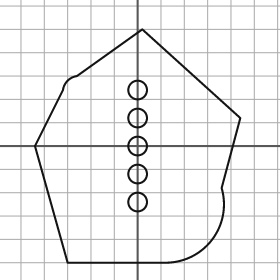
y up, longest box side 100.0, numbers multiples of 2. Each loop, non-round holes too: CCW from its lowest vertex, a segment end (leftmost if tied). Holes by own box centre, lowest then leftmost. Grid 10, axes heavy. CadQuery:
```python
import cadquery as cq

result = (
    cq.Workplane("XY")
    .moveTo(-30.0, -50.0)
    .lineTo(12.0, -50.0)
    .threePointArc((32.0, -40.0), (36.0, -18.0))
    .lineTo(44.0, 12.0)
    .lineTo(2.0, 50.0)
    .lineTo(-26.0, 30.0)
    .threePointArc((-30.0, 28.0), (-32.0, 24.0))
    .lineTo(-44.0, 0.0)
    .close()
    .moveTo(0.0, -24.0)
    .circle(4.0)
    .moveTo(0.0, -12.0)
    .circle(4.0)
    .moveTo(0.0, 0.0)
    .circle(4.0)
    .moveTo(0.0, 12.0)
    .circle(4.0)
    .moveTo(0.0, 24.0)
    .circle(4.0)
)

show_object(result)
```